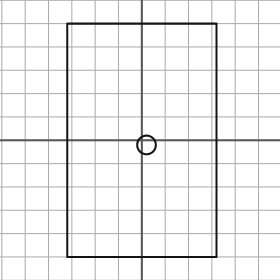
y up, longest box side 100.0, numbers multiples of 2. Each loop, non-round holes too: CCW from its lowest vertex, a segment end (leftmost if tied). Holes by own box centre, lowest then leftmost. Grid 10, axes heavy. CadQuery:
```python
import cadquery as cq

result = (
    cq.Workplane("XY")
    .moveTo(-32.0, -50.0)
    .lineTo(32.0, -50.0)
    .lineTo(32.0, 50.0)
    .lineTo(-32.0, 50.0)
    .close()
    .moveTo(2.0, -2.0)
    .circle(4.0)
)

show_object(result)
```